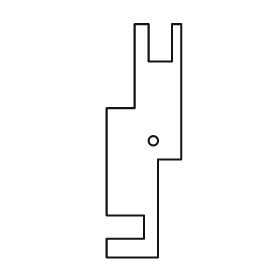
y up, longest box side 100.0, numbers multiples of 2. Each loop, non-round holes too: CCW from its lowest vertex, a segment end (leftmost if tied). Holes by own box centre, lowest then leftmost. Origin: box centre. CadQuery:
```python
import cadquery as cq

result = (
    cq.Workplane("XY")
    .moveTo(-16.0, -50.0)
    .lineTo(6.0, -50.0)
    .lineTo(6.0, -8.0)
    .lineTo(16.0, -8.0)
    .lineTo(16.0, 50.0)
    .lineTo(12.0, 50.0)
    .lineTo(12.0, 34.0)
    .lineTo(2.0, 34.0)
    .lineTo(2.0, 50.0)
    .lineTo(-4.0, 50.0)
    .lineTo(-4.0, 14.0)
    .lineTo(-16.0, 14.0)
    .lineTo(-16.0, -32.0)
    .lineTo(0.0, -32.0)
    .lineTo(0.0, -42.0)
    .lineTo(-16.0, -42.0)
    .close()
    .moveTo(4.0, 0.0)
    .circle(2.0)
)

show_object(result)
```